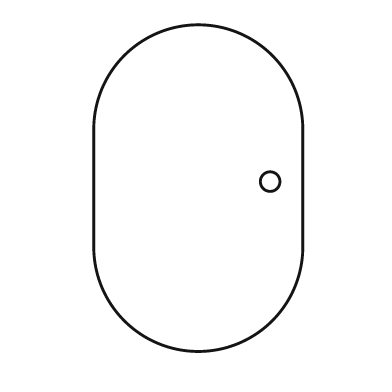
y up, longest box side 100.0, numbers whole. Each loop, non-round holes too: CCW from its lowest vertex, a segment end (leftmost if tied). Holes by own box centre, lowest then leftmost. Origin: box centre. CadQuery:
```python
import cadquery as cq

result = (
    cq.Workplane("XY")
    .moveTo(-32.0, -18.0)
    .threePointArc((0.0, -50.0), (32.0, -18.0))
    .lineTo(32.0, 18.0)
    .threePointArc((0.0, 50.0), (-32.0, 18.0))
    .close()
    .moveTo(22.0, 2.0)
    .circle(3.0)
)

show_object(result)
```